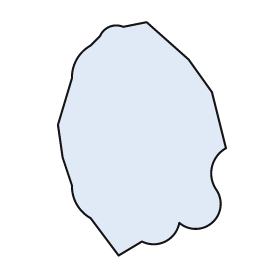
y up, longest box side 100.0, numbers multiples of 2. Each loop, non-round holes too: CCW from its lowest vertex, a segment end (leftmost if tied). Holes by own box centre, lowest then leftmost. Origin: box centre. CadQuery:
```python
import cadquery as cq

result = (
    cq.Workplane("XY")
    .moveTo(-10.0, -50.0)
    .lineTo(0.0, -44.0)
    .threePointArc((10.0, -44.0), (16.0, -36.0))
    .threePointArc((30.0, -36.0), (32.0, -22.0))
    .threePointArc((30.0, -12.0), (36.0, -4.0))
    .lineTo(30.0, 20.0)
    .lineTo(20.0, 34.0)
    .lineTo(2.0, 50.0)
    .lineTo(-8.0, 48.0)
    .threePointArc((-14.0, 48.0), (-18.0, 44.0))
    .lineTo(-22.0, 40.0)
    .threePointArc((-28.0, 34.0), (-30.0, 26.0))
    .lineTo(-36.0, 6.0)
    .lineTo(-34.0, -8.0)
    .lineTo(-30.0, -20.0)
    .threePointArc((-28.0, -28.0), (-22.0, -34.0))
    .close()
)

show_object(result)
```